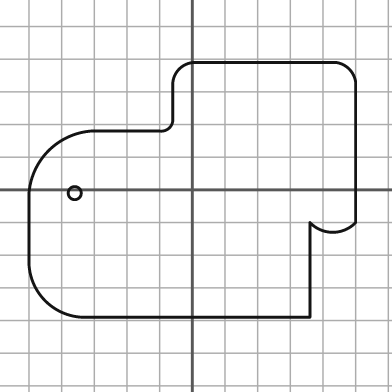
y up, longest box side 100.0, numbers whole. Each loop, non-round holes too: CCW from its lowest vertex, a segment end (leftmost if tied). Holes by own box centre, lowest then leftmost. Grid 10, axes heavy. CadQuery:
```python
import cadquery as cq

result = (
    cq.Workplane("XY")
    .moveTo(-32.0, -39.0)
    .lineTo(36.0, -39.0)
    .lineTo(36.0, -10.0)
    .threePointArc((43.0, -13.0), (50.0, -10.0))
    .lineTo(50.0, 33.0)
    .threePointArc((48.0, 37.0), (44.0, 39.0))
    .lineTo(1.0, 39.0)
    .threePointArc((-4.0, 37.0), (-6.0, 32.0))
    .lineTo(-6.0, 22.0)
    .threePointArc((-7.0, 19.0), (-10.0, 18.0))
    .lineTo(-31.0, 18.0)
    .threePointArc((-44.0, 12.0), (-50.0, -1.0))
    .lineTo(-50.0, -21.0)
    .threePointArc((-45.0, -34.0), (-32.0, -39.0))
    .close()
    .moveTo(-36.0, -1.0)
    .circle(2.0)
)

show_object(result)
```